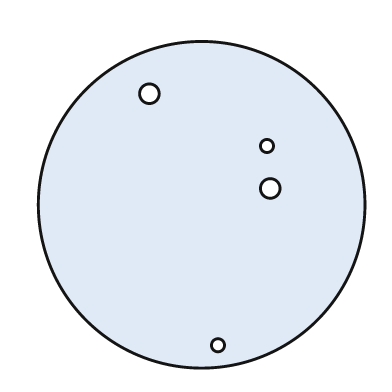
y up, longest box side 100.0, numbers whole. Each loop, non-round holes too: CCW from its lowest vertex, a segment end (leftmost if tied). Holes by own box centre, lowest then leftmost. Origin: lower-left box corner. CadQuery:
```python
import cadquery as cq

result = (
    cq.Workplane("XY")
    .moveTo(50.0, 50.0)
    .circle(50.0)
    .moveTo(55.0, 7.0)
    .circle(2.0)
    .moveTo(71.0, 55.0)
    .circle(3.0)
    .moveTo(70.0, 68.0)
    .circle(2.0)
    .moveTo(34.0, 84.0)
    .circle(3.0)
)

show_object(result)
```